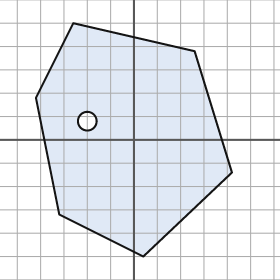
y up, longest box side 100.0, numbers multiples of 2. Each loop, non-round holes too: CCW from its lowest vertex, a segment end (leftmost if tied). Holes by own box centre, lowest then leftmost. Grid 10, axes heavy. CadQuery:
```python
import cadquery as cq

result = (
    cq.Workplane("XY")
    .moveTo(4.0, -50.0)
    .lineTo(42.0, -14.0)
    .lineTo(26.0, 38.0)
    .lineTo(-26.0, 50.0)
    .lineTo(-42.0, 18.0)
    .lineTo(-32.0, -32.0)
    .close()
    .moveTo(-20.0, 8.0)
    .circle(4.0)
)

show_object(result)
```